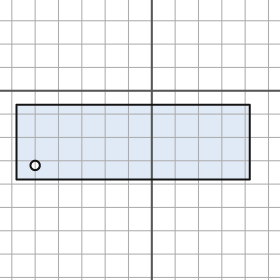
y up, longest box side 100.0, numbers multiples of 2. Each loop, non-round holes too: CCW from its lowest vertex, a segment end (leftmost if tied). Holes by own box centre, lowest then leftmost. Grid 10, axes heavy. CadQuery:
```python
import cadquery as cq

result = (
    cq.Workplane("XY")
    .moveTo(-58.0, -38.0)
    .lineTo(42.0, -38.0)
    .lineTo(42.0, -6.0)
    .lineTo(-58.0, -6.0)
    .close()
    .moveTo(-50.0, -32.0)
    .circle(2.0)
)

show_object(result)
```